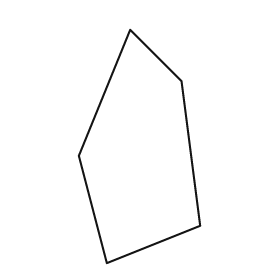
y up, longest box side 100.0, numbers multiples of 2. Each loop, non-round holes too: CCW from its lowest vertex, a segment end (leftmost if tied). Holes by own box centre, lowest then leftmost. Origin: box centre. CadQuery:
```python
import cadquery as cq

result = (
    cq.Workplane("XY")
    .moveTo(-14.0, -50.0)
    .lineTo(26.0, -34.0)
    .lineTo(18.0, 28.0)
    .lineTo(-4.0, 50.0)
    .lineTo(-26.0, -4.0)
    .close()
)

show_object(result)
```